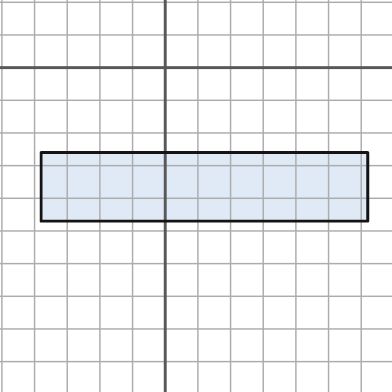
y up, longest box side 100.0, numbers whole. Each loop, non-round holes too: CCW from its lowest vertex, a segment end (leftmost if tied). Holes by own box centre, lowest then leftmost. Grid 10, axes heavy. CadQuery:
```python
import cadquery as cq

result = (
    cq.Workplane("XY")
    .moveTo(-38.0, -47.0)
    .lineTo(62.0, -47.0)
    .lineTo(62.0, -26.0)
    .lineTo(-38.0, -26.0)
    .close()
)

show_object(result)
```